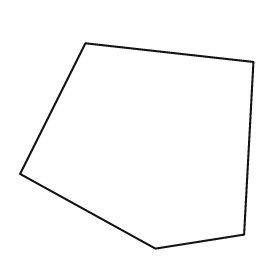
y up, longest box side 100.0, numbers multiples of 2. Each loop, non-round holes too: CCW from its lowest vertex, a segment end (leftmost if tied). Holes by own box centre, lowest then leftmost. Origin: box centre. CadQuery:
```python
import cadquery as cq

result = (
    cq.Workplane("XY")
    .moveTo(8.0, -44.0)
    .lineTo(46.0, -38.0)
    .lineTo(50.0, 36.0)
    .lineTo(-22.0, 44.0)
    .lineTo(-50.0, -12.0)
    .close()
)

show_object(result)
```